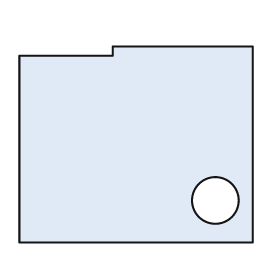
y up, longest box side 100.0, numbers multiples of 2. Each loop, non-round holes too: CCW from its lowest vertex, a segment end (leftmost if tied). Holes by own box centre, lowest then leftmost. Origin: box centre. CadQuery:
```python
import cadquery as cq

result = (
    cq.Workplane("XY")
    .moveTo(-50.0, -42.0)
    .lineTo(50.0, -42.0)
    .lineTo(50.0, 42.0)
    .lineTo(-10.0, 42.0)
    .lineTo(-10.0, 38.0)
    .lineTo(-50.0, 38.0)
    .close()
    .moveTo(34.0, -24.0)
    .circle(10.0)
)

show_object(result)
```